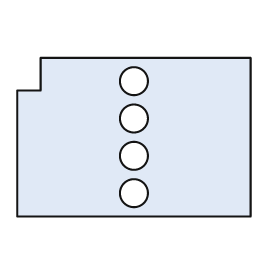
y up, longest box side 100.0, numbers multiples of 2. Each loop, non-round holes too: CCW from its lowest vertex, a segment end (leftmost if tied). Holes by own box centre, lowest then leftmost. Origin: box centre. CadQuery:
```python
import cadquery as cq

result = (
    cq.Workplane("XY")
    .moveTo(-50.0, -34.0)
    .lineTo(50.0, -34.0)
    .lineTo(50.0, 34.0)
    .lineTo(-40.0, 34.0)
    .lineTo(-40.0, 20.0)
    .lineTo(-50.0, 20.0)
    .close()
    .moveTo(0.0, -24.0)
    .circle(6.0)
    .moveTo(0.0, -8.0)
    .circle(6.0)
    .moveTo(0.0, 8.0)
    .circle(6.0)
    .moveTo(0.0, 24.0)
    .circle(6.0)
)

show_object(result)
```